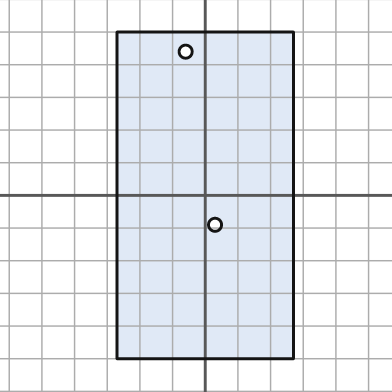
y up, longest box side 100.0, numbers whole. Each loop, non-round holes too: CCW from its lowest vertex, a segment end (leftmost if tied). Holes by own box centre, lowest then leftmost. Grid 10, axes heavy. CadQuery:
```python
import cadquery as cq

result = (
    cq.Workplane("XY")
    .moveTo(-27.0, -50.0)
    .lineTo(27.0, -50.0)
    .lineTo(27.0, 50.0)
    .lineTo(-27.0, 50.0)
    .close()
    .moveTo(3.0, -9.0)
    .circle(2.0)
    .moveTo(-6.0, 44.0)
    .circle(2.0)
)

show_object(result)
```